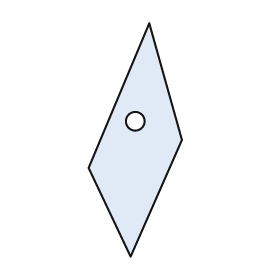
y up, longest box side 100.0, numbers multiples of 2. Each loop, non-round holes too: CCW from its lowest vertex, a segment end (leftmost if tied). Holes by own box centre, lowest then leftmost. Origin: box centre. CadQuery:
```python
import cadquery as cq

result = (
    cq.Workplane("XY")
    .moveTo(-2.0, -50.0)
    .lineTo(20.0, 0.0)
    .lineTo(6.0, 50.0)
    .lineTo(-20.0, -12.0)
    .close()
    .moveTo(0.0, 8.0)
    .circle(4.0)
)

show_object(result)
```